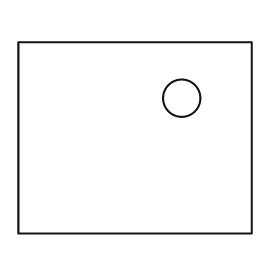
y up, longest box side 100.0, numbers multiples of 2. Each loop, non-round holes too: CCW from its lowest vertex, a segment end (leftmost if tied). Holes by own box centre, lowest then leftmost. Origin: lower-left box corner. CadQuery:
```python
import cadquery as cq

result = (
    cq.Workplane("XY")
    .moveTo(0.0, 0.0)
    .lineTo(100.0, 0.0)
    .lineTo(100.0, 82.0)
    .lineTo(0.0, 82.0)
    .close()
    .moveTo(70.0, 58.0)
    .circle(8.0)
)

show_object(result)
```